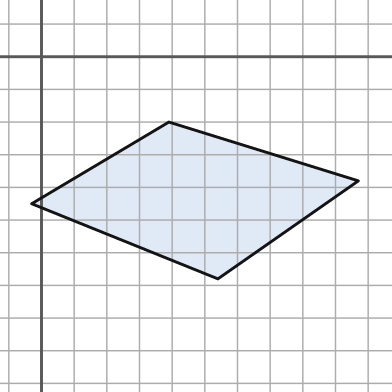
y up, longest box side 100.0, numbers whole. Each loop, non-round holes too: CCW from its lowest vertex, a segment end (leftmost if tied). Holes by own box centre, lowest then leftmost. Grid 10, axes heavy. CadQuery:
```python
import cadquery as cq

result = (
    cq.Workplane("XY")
    .moveTo(54.0, -68.0)
    .lineTo(97.0, -38.0)
    .lineTo(39.0, -20.0)
    .lineTo(-3.0, -45.0)
    .close()
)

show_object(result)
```